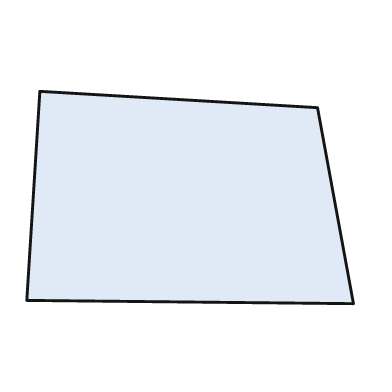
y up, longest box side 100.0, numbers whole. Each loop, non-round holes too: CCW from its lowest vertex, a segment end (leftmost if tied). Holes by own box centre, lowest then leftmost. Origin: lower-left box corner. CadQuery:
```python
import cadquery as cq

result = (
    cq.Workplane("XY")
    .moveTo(100.0, 0.0)
    .lineTo(89.0, 60.0)
    .lineTo(4.0, 65.0)
    .lineTo(0.0, 1.0)
    .close()
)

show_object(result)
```